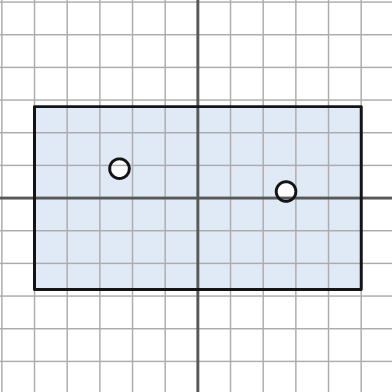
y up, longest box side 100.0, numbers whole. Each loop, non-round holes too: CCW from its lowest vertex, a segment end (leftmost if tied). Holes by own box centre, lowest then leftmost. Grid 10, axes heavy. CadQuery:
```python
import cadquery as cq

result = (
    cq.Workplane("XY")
    .moveTo(-50.0, -28.0)
    .lineTo(50.0, -28.0)
    .lineTo(50.0, 28.0)
    .lineTo(-50.0, 28.0)
    .close()
    .moveTo(27.0, 2.0)
    .circle(3.0)
    .moveTo(-24.0, 9.0)
    .circle(3.0)
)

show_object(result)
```